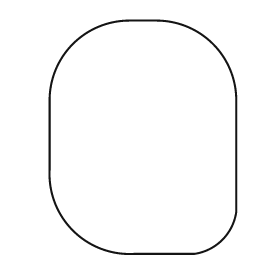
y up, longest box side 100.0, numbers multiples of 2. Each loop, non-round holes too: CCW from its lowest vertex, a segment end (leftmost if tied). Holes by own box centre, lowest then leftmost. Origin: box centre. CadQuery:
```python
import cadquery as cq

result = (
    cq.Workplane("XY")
    .moveTo(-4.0, -50.0)
    .lineTo(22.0, -50.0)
    .threePointArc((34.0, -44.0), (40.0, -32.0))
    .lineTo(40.0, 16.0)
    .threePointArc((30.0, 40.0), (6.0, 50.0))
    .lineTo(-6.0, 50.0)
    .threePointArc((-30.0, 40.0), (-40.0, 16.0))
    .lineTo(-40.0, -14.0)
    .threePointArc((-30.0, -40.0), (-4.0, -50.0))
    .close()
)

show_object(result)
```